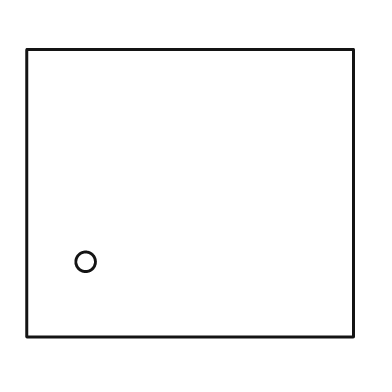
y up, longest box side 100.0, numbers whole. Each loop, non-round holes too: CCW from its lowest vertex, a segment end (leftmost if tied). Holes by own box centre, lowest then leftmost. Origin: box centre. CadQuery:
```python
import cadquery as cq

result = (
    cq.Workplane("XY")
    .moveTo(-50.0, -44.0)
    .lineTo(50.0, -44.0)
    .lineTo(50.0, 44.0)
    .lineTo(-50.0, 44.0)
    .close()
    .moveTo(-32.0, -21.0)
    .circle(3.0)
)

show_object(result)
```